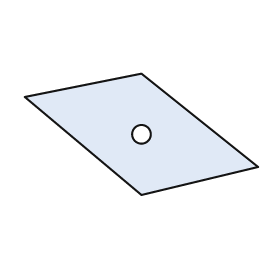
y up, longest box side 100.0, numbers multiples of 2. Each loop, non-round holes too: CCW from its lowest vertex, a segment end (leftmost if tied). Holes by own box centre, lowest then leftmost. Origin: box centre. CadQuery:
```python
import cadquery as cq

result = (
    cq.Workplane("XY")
    .moveTo(0.0, -26.0)
    .lineTo(50.0, -14.0)
    .lineTo(0.0, 26.0)
    .lineTo(-50.0, 16.0)
    .close()
    .moveTo(0.0, 0.0)
    .circle(4.0)
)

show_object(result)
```